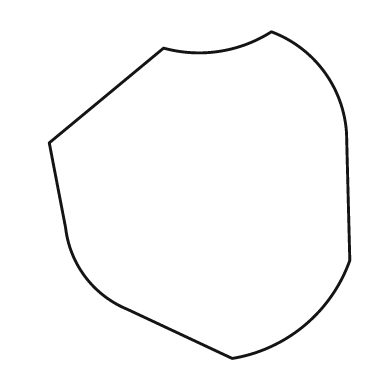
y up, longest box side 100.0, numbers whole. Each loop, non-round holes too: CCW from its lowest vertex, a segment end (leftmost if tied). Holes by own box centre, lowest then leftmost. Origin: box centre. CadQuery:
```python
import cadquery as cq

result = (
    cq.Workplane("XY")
    .moveTo(10.0, -50.0)
    .threePointArc((32.0, -40.0), (46.0, -20.0))
    .lineTo(45.0, 19.0)
    .threePointArc((38.0, 38.0), (22.0, 50.0))
    .threePointArc((6.0, 44.0), (-11.0, 45.0))
    .lineTo(-46.0, 16.0)
    .lineTo(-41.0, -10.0)
    .threePointArc((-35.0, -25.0), (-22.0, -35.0))
    .close()
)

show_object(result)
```